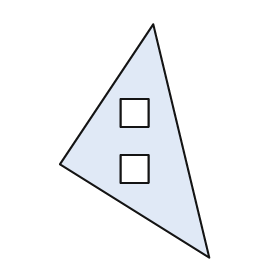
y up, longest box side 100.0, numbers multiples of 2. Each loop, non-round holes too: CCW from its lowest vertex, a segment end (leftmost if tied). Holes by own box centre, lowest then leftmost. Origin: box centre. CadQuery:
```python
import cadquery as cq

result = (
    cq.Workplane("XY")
    .moveTo(32.0, -50.0)
    .lineTo(8.0, 50.0)
    .lineTo(-32.0, -10.0)
    .close()
    .moveTo(-6.0, -18.0)
    .lineTo(6.0, -18.0)
    .lineTo(6.0, -6.0)
    .lineTo(-6.0, -6.0)
    .close()
    .moveTo(-6.0, 6.0)
    .lineTo(6.0, 6.0)
    .lineTo(6.0, 18.0)
    .lineTo(-6.0, 18.0)
    .close()
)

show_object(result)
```